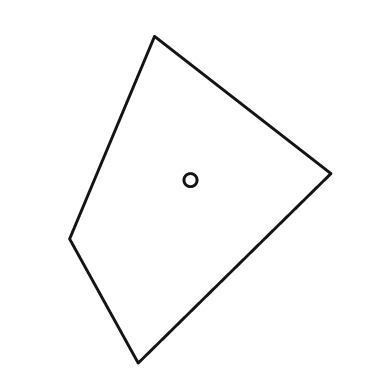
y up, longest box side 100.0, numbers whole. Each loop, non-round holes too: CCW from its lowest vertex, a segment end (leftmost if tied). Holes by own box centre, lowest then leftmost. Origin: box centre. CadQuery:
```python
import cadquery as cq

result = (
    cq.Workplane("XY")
    .moveTo(-19.0, -50.0)
    .lineTo(40.0, 8.0)
    .lineTo(-14.0, 50.0)
    .lineTo(-40.0, -12.0)
    .close()
    .moveTo(-3.0, 6.0)
    .circle(2.0)
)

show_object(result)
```